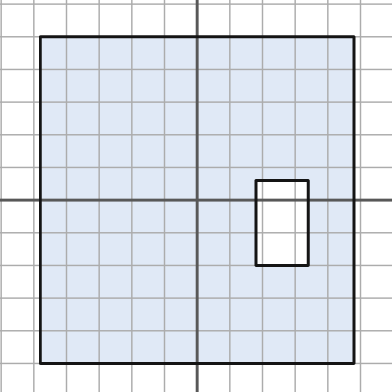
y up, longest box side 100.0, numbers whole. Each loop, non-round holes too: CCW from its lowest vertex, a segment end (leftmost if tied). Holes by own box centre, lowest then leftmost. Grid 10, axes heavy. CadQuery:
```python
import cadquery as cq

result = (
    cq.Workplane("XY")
    .moveTo(-48.0, -50.0)
    .lineTo(48.0, -50.0)
    .lineTo(48.0, 50.0)
    .lineTo(-48.0, 50.0)
    .close()
    .moveTo(18.0, -20.0)
    .lineTo(34.0, -20.0)
    .lineTo(34.0, 6.0)
    .lineTo(18.0, 6.0)
    .close()
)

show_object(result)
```